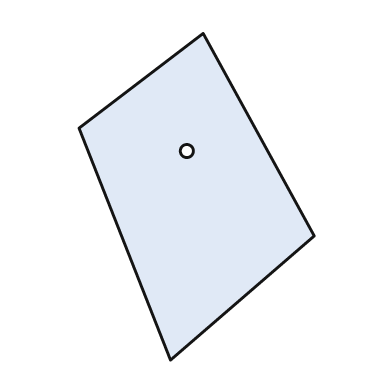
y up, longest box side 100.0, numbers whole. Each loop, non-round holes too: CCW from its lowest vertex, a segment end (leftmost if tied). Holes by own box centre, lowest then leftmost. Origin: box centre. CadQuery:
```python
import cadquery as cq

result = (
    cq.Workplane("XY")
    .moveTo(-8.0, -50.0)
    .lineTo(36.0, -12.0)
    .lineTo(2.0, 50.0)
    .lineTo(-36.0, 21.0)
    .close()
    .moveTo(-3.0, 14.0)
    .circle(2.0)
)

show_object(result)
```